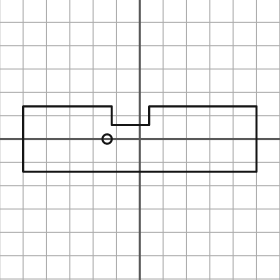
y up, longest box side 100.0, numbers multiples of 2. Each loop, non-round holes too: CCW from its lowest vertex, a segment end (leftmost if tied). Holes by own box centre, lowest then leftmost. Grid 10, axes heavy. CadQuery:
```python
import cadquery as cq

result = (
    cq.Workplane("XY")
    .moveTo(-50.0, -14.0)
    .lineTo(50.0, -14.0)
    .lineTo(50.0, 14.0)
    .lineTo(4.0, 14.0)
    .lineTo(4.0, 6.0)
    .lineTo(-12.0, 6.0)
    .lineTo(-12.0, 14.0)
    .lineTo(-50.0, 14.0)
    .close()
    .moveTo(-14.0, 0.0)
    .circle(2.0)
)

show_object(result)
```